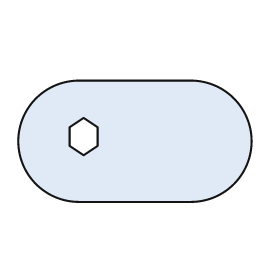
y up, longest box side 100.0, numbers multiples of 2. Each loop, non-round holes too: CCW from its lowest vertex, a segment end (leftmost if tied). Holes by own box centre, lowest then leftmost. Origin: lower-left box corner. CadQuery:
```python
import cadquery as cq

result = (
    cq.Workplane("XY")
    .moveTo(26.0, 0.0)
    .lineTo(74.0, 0.0)
    .threePointArc((100.0, 26.0), (74.0, 52.0))
    .lineTo(26.0, 52.0)
    .threePointArc((0.0, 26.0), (26.0, 0.0))
    .close()
    .moveTo(28.0, 20.0)
    .lineTo(34.0, 24.0)
    .lineTo(34.0, 32.0)
    .lineTo(28.0, 36.0)
    .lineTo(22.0, 32.0)
    .lineTo(22.0, 24.0)
    .close()
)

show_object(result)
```